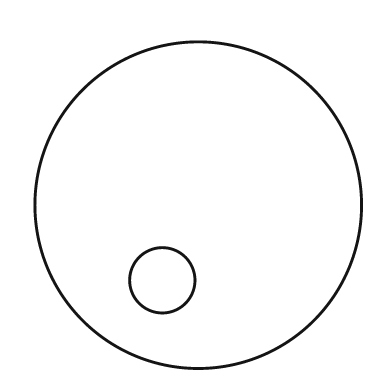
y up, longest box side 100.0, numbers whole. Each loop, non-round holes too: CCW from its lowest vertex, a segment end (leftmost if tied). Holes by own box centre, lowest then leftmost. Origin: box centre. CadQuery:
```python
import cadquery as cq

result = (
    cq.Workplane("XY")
    .moveTo(0.0, 0.0)
    .circle(50.0)
    .moveTo(-11.0, -23.0)
    .circle(10.0)
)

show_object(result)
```